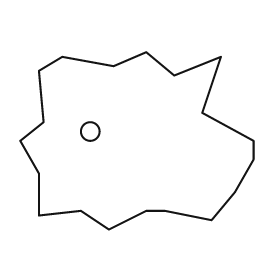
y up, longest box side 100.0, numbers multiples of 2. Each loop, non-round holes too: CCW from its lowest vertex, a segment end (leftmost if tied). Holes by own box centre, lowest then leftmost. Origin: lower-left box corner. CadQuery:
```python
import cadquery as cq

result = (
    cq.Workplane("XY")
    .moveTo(38.0, 0.0)
    .lineTo(54.0, 8.0)
    .lineTo(62.0, 8.0)
    .lineTo(82.0, 4.0)
    .lineTo(92.0, 16.0)
    .lineTo(100.0, 30.0)
    .lineTo(100.0, 38.0)
    .lineTo(78.0, 50.0)
    .lineTo(86.0, 74.0)
    .lineTo(66.0, 66.0)
    .lineTo(54.0, 76.0)
    .lineTo(40.0, 70.0)
    .lineTo(18.0, 74.0)
    .lineTo(8.0, 68.0)
    .lineTo(10.0, 46.0)
    .lineTo(0.0, 38.0)
    .lineTo(8.0, 24.0)
    .lineTo(8.0, 6.0)
    .lineTo(26.0, 8.0)
    .close()
    .moveTo(30.0, 42.0)
    .circle(4.0)
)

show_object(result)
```